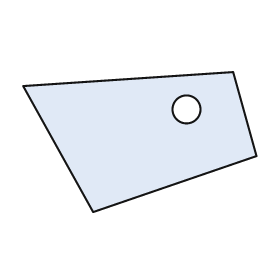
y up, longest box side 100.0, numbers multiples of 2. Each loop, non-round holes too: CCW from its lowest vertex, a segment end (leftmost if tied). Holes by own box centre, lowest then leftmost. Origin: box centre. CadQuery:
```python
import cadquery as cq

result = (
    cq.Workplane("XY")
    .moveTo(-20.0, -30.0)
    .lineTo(50.0, -6.0)
    .lineTo(40.0, 30.0)
    .lineTo(-50.0, 24.0)
    .close()
    .moveTo(20.0, 14.0)
    .circle(6.0)
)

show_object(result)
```